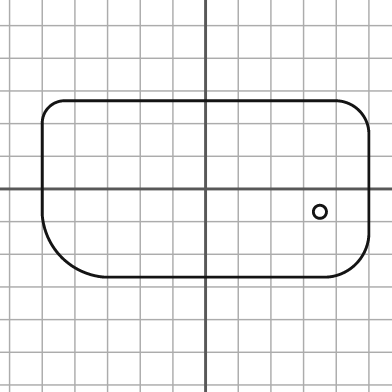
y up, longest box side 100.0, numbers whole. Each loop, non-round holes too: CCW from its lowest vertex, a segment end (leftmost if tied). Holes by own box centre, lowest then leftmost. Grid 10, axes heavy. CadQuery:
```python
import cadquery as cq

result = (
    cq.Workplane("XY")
    .moveTo(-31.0, -27.0)
    .lineTo(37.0, -27.0)
    .threePointArc((46.0, -23.0), (50.0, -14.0))
    .lineTo(50.0, 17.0)
    .threePointArc((47.0, 24.0), (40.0, 27.0))
    .lineTo(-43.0, 27.0)
    .threePointArc((-48.0, 25.0), (-50.0, 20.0))
    .lineTo(-50.0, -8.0)
    .threePointArc((-44.0, -21.0), (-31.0, -27.0))
    .close()
    .moveTo(35.0, -7.0)
    .circle(2.0)
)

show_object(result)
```